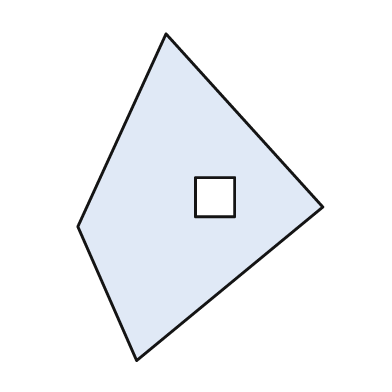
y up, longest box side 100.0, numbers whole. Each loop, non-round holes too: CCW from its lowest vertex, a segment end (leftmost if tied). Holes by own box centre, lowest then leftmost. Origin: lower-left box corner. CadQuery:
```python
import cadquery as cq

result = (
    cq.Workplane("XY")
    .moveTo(18.0, 0.0)
    .lineTo(75.0, 47.0)
    .lineTo(27.0, 100.0)
    .lineTo(0.0, 41.0)
    .close()
    .moveTo(36.0, 44.0)
    .lineTo(48.0, 44.0)
    .lineTo(48.0, 56.0)
    .lineTo(36.0, 56.0)
    .close()
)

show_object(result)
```